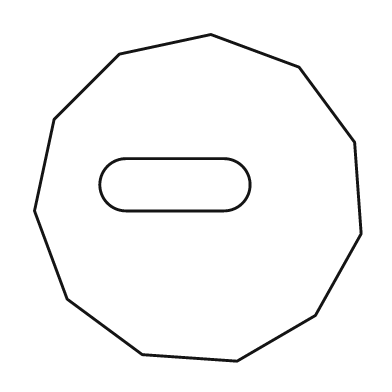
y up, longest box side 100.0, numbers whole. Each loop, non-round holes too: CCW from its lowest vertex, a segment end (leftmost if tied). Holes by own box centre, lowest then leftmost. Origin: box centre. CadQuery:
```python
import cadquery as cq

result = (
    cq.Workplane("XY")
    .moveTo(12.0, -50.0)
    .lineTo(36.0, -36.0)
    .lineTo(50.0, -11.0)
    .lineTo(48.0, 17.0)
    .lineTo(31.0, 40.0)
    .lineTo(4.0, 50.0)
    .lineTo(-24.0, 44.0)
    .lineTo(-44.0, 24.0)
    .lineTo(-50.0, -4.0)
    .lineTo(-40.0, -31.0)
    .lineTo(-17.0, -48.0)
    .close()
    .moveTo(-22.0, -4.0)
    .lineTo(8.0, -4.0)
    .threePointArc((16.0, 4.0), (8.0, 12.0))
    .lineTo(-22.0, 12.0)
    .threePointArc((-30.0, 4.0), (-22.0, -4.0))
    .close()
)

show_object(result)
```